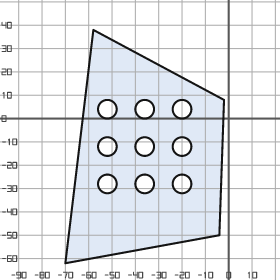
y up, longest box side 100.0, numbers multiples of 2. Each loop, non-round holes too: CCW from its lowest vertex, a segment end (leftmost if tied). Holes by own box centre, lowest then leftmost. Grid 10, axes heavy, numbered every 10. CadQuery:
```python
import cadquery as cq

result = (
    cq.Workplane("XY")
    .moveTo(-70.0, -62.0)
    .lineTo(-4.0, -50.0)
    .lineTo(-2.0, 8.0)
    .lineTo(-58.0, 38.0)
    .close()
    .moveTo(-52.0, -28.0)
    .circle(4.0)
    .moveTo(-36.0, -28.0)
    .circle(4.0)
    .moveTo(-20.0, -28.0)
    .circle(4.0)
    .moveTo(-52.0, -12.0)
    .circle(4.0)
    .moveTo(-36.0, -12.0)
    .circle(4.0)
    .moveTo(-20.0, -12.0)
    .circle(4.0)
    .moveTo(-52.0, 4.0)
    .circle(4.0)
    .moveTo(-36.0, 4.0)
    .circle(4.0)
    .moveTo(-20.0, 4.0)
    .circle(4.0)
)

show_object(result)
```